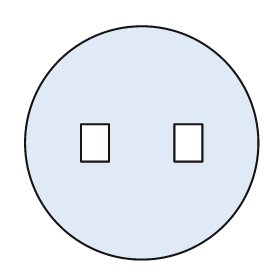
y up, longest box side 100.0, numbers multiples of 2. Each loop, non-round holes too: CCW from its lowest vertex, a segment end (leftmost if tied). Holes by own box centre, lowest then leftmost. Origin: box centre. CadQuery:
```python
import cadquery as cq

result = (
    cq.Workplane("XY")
    .moveTo(0.0, 0.0)
    .circle(50.0)
    .moveTo(-26.0, -8.0)
    .lineTo(-14.0, -8.0)
    .lineTo(-14.0, 8.0)
    .lineTo(-26.0, 8.0)
    .close()
    .moveTo(14.0, -8.0)
    .lineTo(26.0, -8.0)
    .lineTo(26.0, 8.0)
    .lineTo(14.0, 8.0)
    .close()
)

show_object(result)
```